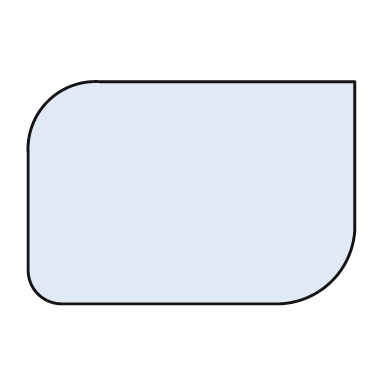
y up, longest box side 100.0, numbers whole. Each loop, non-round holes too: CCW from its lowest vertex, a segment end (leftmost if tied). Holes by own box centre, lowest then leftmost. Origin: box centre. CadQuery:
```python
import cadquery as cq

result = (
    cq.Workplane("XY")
    .moveTo(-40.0, -34.0)
    .lineTo(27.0, -34.0)
    .threePointArc((43.0, -27.0), (50.0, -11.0))
    .lineTo(50.0, 34.0)
    .lineTo(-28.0, 34.0)
    .threePointArc((-44.0, 28.0), (-50.0, 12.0))
    .lineTo(-50.0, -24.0)
    .threePointArc((-47.0, -31.0), (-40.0, -34.0))
    .close()
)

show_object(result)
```